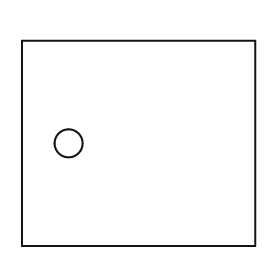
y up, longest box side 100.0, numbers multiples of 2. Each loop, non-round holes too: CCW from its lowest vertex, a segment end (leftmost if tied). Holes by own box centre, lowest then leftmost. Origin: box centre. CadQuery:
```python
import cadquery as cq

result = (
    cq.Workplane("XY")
    .moveTo(-50.0, -44.0)
    .lineTo(50.0, -44.0)
    .lineTo(50.0, 44.0)
    .lineTo(-50.0, 44.0)
    .close()
    .moveTo(-30.0, 0.0)
    .circle(6.0)
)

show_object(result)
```